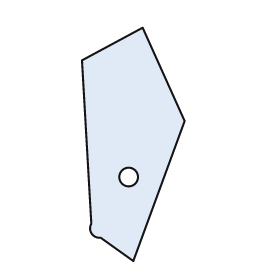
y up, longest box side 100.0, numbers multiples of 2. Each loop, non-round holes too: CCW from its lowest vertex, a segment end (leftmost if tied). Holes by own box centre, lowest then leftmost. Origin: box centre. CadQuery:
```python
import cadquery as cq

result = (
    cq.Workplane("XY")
    .moveTo(0.0, -50.0)
    .lineTo(22.0, 10.0)
    .lineTo(4.0, 50.0)
    .lineTo(-22.0, 36.0)
    .lineTo(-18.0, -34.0)
    .threePointArc((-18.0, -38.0), (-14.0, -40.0))
    .close()
    .moveTo(-2.0, -14.0)
    .circle(4.0)
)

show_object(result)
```